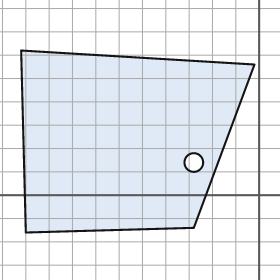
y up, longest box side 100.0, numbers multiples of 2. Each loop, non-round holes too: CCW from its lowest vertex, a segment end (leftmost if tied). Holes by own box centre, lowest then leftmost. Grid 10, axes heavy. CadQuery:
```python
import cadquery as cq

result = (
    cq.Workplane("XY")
    .moveTo(-100.0, -16.0)
    .lineTo(-28.0, -14.0)
    .lineTo(-2.0, 56.0)
    .lineTo(-102.0, 62.0)
    .close()
    .moveTo(-28.0, 14.0)
    .circle(4.0)
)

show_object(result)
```